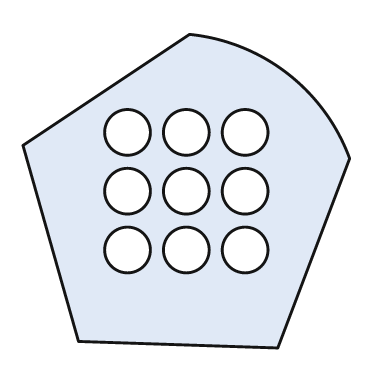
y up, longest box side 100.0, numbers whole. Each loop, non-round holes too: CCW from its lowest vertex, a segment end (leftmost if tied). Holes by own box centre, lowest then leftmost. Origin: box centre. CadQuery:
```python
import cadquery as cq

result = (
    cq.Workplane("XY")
    .moveTo(28.0, -48.0)
    .lineTo(50.0, 10.0)
    .threePointArc((31.0, 36.0), (1.0, 48.0))
    .lineTo(-50.0, 14.0)
    .lineTo(-33.0, -46.0)
    .close()
    .moveTo(-18.0, -18.0)
    .circle(7.0)
    .moveTo(0.0, -18.0)
    .circle(7.0)
    .moveTo(18.0, -18.0)
    .circle(7.0)
    .moveTo(-18.0, 0.0)
    .circle(7.0)
    .moveTo(0.0, 0.0)
    .circle(7.0)
    .moveTo(18.0, 0.0)
    .circle(7.0)
    .moveTo(-18.0, 18.0)
    .circle(7.0)
    .moveTo(0.0, 18.0)
    .circle(7.0)
    .moveTo(18.0, 18.0)
    .circle(7.0)
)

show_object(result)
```